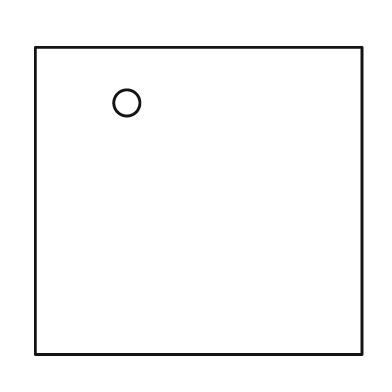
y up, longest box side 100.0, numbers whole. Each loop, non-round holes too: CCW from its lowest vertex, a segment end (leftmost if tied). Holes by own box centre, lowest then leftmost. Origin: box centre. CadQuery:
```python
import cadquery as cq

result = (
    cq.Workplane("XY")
    .moveTo(-50.0, -47.0)
    .lineTo(50.0, -47.0)
    .lineTo(50.0, 47.0)
    .lineTo(-50.0, 47.0)
    .close()
    .moveTo(-22.0, 30.0)
    .circle(4.0)
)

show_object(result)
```